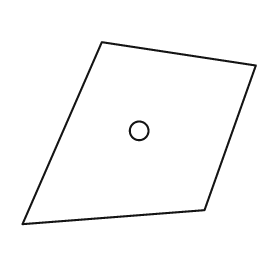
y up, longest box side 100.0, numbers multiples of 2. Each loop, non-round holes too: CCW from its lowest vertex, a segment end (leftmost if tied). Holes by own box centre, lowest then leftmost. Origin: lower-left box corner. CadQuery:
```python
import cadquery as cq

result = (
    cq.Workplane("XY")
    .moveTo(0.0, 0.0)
    .lineTo(78.0, 6.0)
    .lineTo(100.0, 68.0)
    .lineTo(34.0, 78.0)
    .close()
    .moveTo(50.0, 40.0)
    .circle(4.0)
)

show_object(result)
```